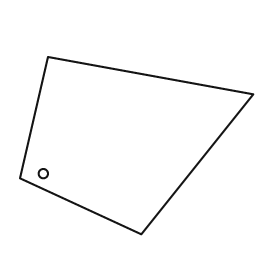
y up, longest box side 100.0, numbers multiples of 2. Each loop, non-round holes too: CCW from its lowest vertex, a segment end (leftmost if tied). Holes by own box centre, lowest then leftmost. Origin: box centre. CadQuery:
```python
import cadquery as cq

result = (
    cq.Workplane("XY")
    .moveTo(2.0, -38.0)
    .lineTo(50.0, 22.0)
    .lineTo(-38.0, 38.0)
    .lineTo(-50.0, -14.0)
    .close()
    .moveTo(-40.0, -12.0)
    .circle(2.0)
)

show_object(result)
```